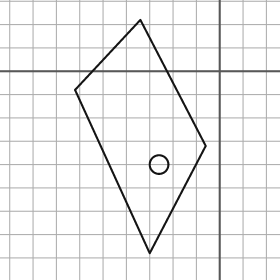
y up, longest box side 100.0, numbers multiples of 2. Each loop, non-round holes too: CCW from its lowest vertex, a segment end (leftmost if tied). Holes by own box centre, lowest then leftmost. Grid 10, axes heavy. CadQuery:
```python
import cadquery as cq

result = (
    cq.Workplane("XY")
    .moveTo(-30.0, -78.0)
    .lineTo(-6.0, -32.0)
    .lineTo(-34.0, 22.0)
    .lineTo(-62.0, -8.0)
    .close()
    .moveTo(-26.0, -40.0)
    .circle(4.0)
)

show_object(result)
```